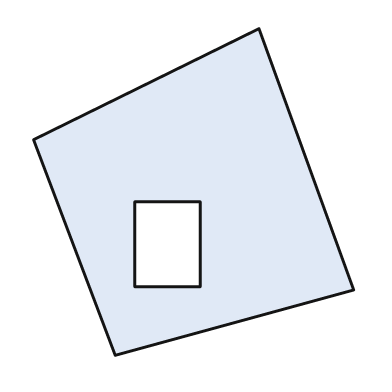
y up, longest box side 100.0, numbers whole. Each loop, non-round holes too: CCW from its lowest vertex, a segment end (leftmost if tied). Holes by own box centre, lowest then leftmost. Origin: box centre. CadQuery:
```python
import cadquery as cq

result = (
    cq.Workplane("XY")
    .moveTo(-24.0, -50.0)
    .lineTo(49.0, -30.0)
    .lineTo(20.0, 50.0)
    .lineTo(-49.0, 16.0)
    .close()
    .moveTo(-18.0, -29.0)
    .lineTo(2.0, -29.0)
    .lineTo(2.0, -3.0)
    .lineTo(-18.0, -3.0)
    .close()
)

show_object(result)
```